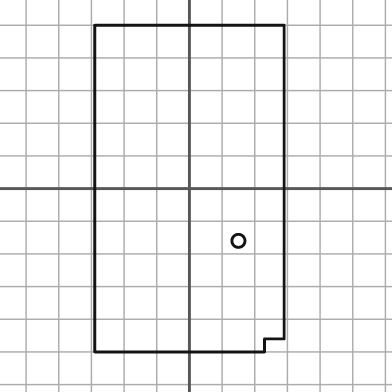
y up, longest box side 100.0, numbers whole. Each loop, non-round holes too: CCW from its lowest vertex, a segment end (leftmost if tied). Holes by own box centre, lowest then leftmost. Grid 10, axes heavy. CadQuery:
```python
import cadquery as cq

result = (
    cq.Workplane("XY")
    .moveTo(-29.0, -50.0)
    .lineTo(23.0, -50.0)
    .lineTo(23.0, -46.0)
    .lineTo(29.0, -46.0)
    .lineTo(29.0, 50.0)
    .lineTo(-29.0, 50.0)
    .close()
    .moveTo(15.0, -16.0)
    .circle(2.0)
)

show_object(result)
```